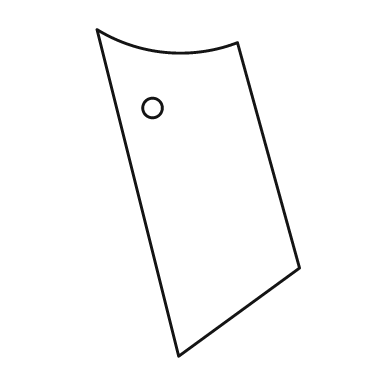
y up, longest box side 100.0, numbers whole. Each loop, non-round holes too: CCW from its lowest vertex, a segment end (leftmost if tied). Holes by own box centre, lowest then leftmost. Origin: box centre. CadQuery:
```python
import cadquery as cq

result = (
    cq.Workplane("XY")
    .moveTo(-6.0, -50.0)
    .lineTo(31.0, -23.0)
    .lineTo(12.0, 46.0)
    .threePointArc((-10.0, 43.0), (-31.0, 50.0))
    .close()
    .moveTo(-14.0, 26.0)
    .circle(3.0)
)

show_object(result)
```